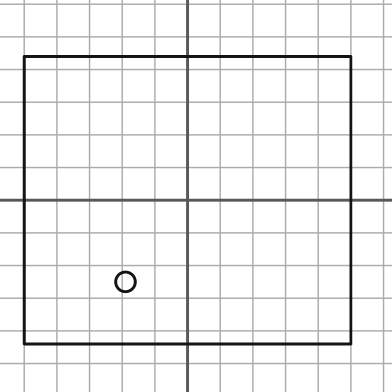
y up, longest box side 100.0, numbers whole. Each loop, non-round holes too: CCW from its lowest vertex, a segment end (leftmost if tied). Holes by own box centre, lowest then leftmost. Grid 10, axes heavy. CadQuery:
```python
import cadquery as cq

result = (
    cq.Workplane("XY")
    .moveTo(-50.0, -44.0)
    .lineTo(50.0, -44.0)
    .lineTo(50.0, 44.0)
    .lineTo(-50.0, 44.0)
    .close()
    .moveTo(-19.0, -25.0)
    .circle(3.0)
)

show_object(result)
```